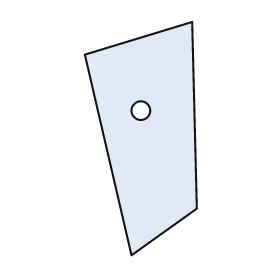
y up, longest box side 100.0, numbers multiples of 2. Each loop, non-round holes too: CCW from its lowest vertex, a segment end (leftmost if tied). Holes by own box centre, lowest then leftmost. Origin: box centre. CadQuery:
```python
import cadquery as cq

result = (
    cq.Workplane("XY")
    .moveTo(-4.0, -50.0)
    .lineTo(24.0, -30.0)
    .lineTo(22.0, 50.0)
    .lineTo(-24.0, 36.0)
    .close()
    .moveTo(0.0, 12.0)
    .circle(4.0)
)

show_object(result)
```